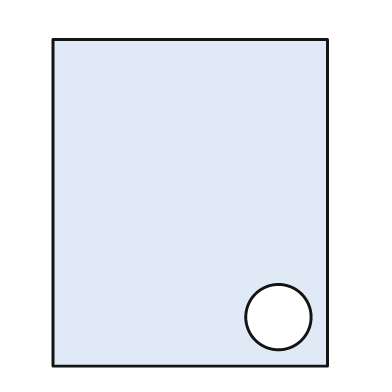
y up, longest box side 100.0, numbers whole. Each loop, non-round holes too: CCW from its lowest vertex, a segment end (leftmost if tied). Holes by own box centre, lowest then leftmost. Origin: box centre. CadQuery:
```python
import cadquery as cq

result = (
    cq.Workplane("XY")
    .moveTo(-42.0, -50.0)
    .lineTo(42.0, -50.0)
    .lineTo(42.0, 50.0)
    .lineTo(-42.0, 50.0)
    .close()
    .moveTo(27.0, -35.0)
    .circle(10.0)
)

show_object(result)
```